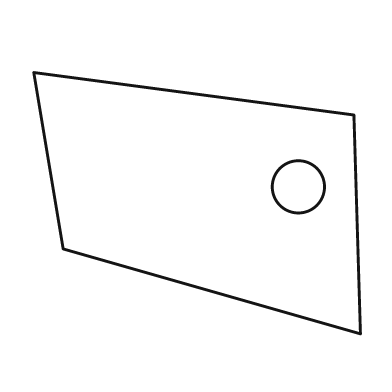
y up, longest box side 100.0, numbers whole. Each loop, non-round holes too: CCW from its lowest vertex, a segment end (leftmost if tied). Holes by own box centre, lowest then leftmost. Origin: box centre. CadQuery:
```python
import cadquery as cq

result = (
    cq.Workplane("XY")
    .moveTo(50.0, -40.0)
    .lineTo(48.0, 27.0)
    .lineTo(-50.0, 40.0)
    .lineTo(-41.0, -14.0)
    .close()
    .moveTo(31.0, 5.0)
    .circle(8.0)
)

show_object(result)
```